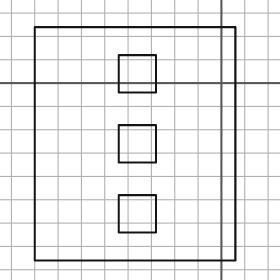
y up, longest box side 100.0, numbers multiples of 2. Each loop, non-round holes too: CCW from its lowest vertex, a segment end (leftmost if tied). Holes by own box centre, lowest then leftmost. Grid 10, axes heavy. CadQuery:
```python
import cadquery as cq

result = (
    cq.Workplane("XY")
    .moveTo(-80.0, -76.0)
    .lineTo(6.0, -76.0)
    .lineTo(6.0, 24.0)
    .lineTo(-80.0, 24.0)
    .close()
    .moveTo(-44.0, -64.0)
    .lineTo(-28.0, -64.0)
    .lineTo(-28.0, -48.0)
    .lineTo(-44.0, -48.0)
    .close()
    .moveTo(-44.0, -34.0)
    .lineTo(-28.0, -34.0)
    .lineTo(-28.0, -18.0)
    .lineTo(-44.0, -18.0)
    .close()
    .moveTo(-44.0, -4.0)
    .lineTo(-28.0, -4.0)
    .lineTo(-28.0, 12.0)
    .lineTo(-44.0, 12.0)
    .close()
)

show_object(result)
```